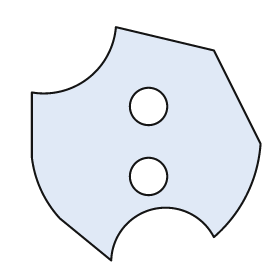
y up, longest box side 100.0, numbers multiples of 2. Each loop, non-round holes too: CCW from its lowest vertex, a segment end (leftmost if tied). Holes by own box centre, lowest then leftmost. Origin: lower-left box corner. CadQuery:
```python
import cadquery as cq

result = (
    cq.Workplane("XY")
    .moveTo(34.0, 0.0)
    .threePointArc((52.0, 22.0), (78.0, 10.0))
    .threePointArc((92.0, 28.0), (98.0, 50.0))
    .lineTo(78.0, 90.0)
    .lineTo(36.0, 100.0)
    .threePointArc((24.0, 78.0), (0.0, 72.0))
    .lineTo(0.0, 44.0)
    .threePointArc((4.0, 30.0), (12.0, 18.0))
    .close()
    .moveTo(50.0, 36.0)
    .circle(8.0)
    .moveTo(50.0, 66.0)
    .circle(8.0)
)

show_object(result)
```